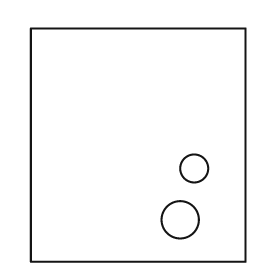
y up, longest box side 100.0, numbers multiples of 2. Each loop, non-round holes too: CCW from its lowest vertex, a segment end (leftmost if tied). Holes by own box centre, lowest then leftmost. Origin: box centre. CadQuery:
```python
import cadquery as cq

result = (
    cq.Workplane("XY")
    .moveTo(-46.0, -50.0)
    .lineTo(46.0, -50.0)
    .lineTo(46.0, 50.0)
    .lineTo(-46.0, 50.0)
    .close()
    .moveTo(18.0, -32.0)
    .circle(8.0)
    .moveTo(24.0, -10.0)
    .circle(6.0)
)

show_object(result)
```